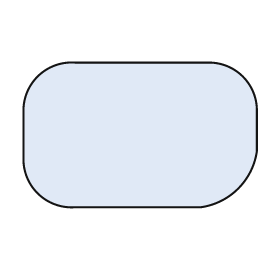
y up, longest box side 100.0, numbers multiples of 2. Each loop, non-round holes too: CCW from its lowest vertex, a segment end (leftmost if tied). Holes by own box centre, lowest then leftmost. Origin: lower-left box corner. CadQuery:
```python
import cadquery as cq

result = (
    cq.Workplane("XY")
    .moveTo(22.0, 0.0)
    .lineTo(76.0, 0.0)
    .threePointArc((92.0, 8.0), (100.0, 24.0))
    .lineTo(100.0, 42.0)
    .threePointArc((94.0, 56.0), (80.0, 62.0))
    .lineTo(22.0, 62.0)
    .threePointArc((6.0, 56.0), (0.0, 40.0))
    .lineTo(0.0, 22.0)
    .threePointArc((6.0, 6.0), (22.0, 0.0))
    .close()
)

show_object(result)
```